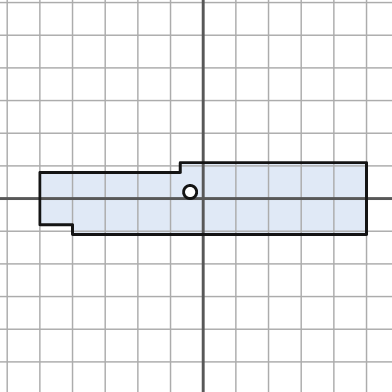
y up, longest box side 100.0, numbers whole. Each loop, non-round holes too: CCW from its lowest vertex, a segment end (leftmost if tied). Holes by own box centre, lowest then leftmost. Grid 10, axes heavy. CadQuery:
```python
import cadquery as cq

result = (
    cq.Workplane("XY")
    .moveTo(-40.0, -11.0)
    .lineTo(50.0, -11.0)
    .lineTo(50.0, 11.0)
    .lineTo(-7.0, 11.0)
    .lineTo(-7.0, 8.0)
    .lineTo(-50.0, 8.0)
    .lineTo(-50.0, -8.0)
    .lineTo(-40.0, -8.0)
    .close()
    .moveTo(-4.0, 2.0)
    .circle(2.0)
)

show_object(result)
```